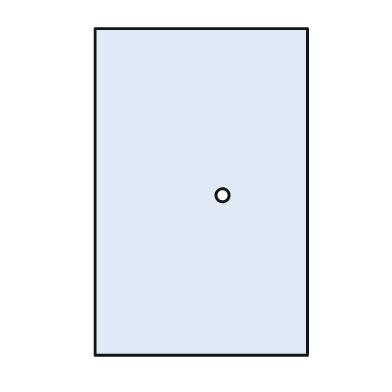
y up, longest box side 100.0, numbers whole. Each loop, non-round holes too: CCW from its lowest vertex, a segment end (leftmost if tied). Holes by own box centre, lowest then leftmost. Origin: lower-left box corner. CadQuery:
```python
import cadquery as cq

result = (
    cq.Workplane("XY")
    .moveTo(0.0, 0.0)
    .lineTo(65.0, 0.0)
    .lineTo(65.0, 100.0)
    .lineTo(0.0, 100.0)
    .close()
    .moveTo(39.0, 49.0)
    .circle(2.0)
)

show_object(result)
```